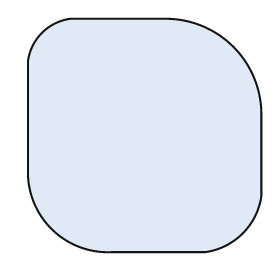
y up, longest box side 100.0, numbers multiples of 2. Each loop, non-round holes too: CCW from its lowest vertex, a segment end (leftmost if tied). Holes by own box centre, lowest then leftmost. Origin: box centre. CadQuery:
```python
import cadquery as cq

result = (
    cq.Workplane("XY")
    .moveTo(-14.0, -50.0)
    .lineTo(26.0, -50.0)
    .threePointArc((42.0, -42.0), (50.0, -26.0))
    .lineTo(50.0, 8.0)
    .threePointArc((38.0, 38.0), (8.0, 50.0))
    .lineTo(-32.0, 50.0)
    .threePointArc((-44.0, 44.0), (-50.0, 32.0))
    .lineTo(-50.0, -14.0)
    .threePointArc((-40.0, -40.0), (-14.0, -50.0))
    .close()
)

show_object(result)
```